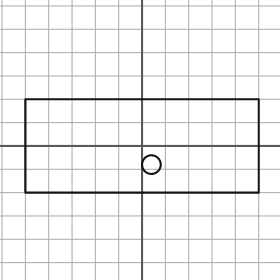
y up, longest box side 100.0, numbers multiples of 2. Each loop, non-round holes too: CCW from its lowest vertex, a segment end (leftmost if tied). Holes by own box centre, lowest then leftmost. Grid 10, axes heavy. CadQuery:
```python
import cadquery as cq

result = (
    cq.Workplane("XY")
    .moveTo(-50.0, -20.0)
    .lineTo(50.0, -20.0)
    .lineTo(50.0, 20.0)
    .lineTo(-50.0, 20.0)
    .close()
    .moveTo(4.0, -8.0)
    .circle(4.0)
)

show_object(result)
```